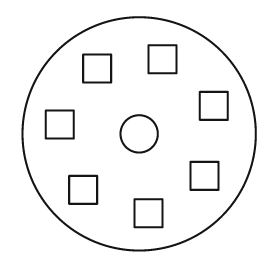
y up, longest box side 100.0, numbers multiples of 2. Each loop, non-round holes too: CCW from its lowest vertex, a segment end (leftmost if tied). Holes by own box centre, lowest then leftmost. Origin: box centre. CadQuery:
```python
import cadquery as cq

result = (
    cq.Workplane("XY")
    .moveTo(0.0, 0.0)
    .circle(50.0)
    .moveTo(-2.0, -40.0)
    .lineTo(10.0, -40.0)
    .lineTo(10.0, -28.0)
    .lineTo(-2.0, -28.0)
    .close()
    .moveTo(-30.0, -30.0)
    .lineTo(-18.0, -30.0)
    .lineTo(-18.0, -18.0)
    .lineTo(-30.0, -18.0)
    .close()
    .moveTo(22.0, -24.0)
    .lineTo(34.0, -24.0)
    .lineTo(34.0, -12.0)
    .lineTo(22.0, -12.0)
    .close()
    .moveTo(0.0, 0.0)
    .circle(8.0)
    .moveTo(-40.0, -2.0)
    .lineTo(-28.0, -2.0)
    .lineTo(-28.0, 10.0)
    .lineTo(-40.0, 10.0)
    .close()
    .moveTo(26.0, 6.0)
    .lineTo(38.0, 6.0)
    .lineTo(38.0, 18.0)
    .lineTo(26.0, 18.0)
    .close()
    .moveTo(-24.0, 22.0)
    .lineTo(-12.0, 22.0)
    .lineTo(-12.0, 34.0)
    .lineTo(-24.0, 34.0)
    .close()
    .moveTo(4.0, 26.0)
    .lineTo(16.0, 26.0)
    .lineTo(16.0, 38.0)
    .lineTo(4.0, 38.0)
    .close()
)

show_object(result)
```